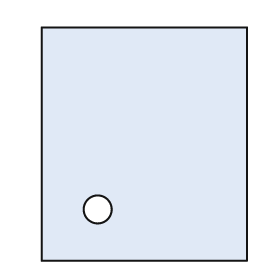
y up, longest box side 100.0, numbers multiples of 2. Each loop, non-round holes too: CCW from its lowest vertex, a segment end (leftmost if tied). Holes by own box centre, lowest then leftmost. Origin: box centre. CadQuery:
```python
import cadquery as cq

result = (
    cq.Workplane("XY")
    .moveTo(-44.0, -50.0)
    .lineTo(44.0, -50.0)
    .lineTo(44.0, 50.0)
    .lineTo(-44.0, 50.0)
    .close()
    .moveTo(-20.0, -28.0)
    .circle(6.0)
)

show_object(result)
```